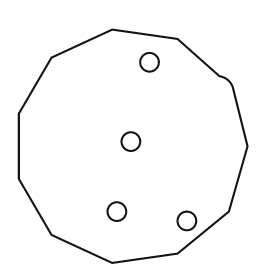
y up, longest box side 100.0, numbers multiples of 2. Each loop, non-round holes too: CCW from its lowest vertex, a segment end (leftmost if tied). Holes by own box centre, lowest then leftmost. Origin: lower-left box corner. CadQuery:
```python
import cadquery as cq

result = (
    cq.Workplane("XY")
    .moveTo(40.0, 0.0)
    .lineTo(68.0, 4.0)
    .lineTo(90.0, 22.0)
    .lineTo(98.0, 50.0)
    .lineTo(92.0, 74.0)
    .threePointArc((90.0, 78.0), (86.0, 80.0))
    .lineTo(68.0, 96.0)
    .lineTo(40.0, 100.0)
    .lineTo(14.0, 88.0)
    .lineTo(0.0, 64.0)
    .lineTo(0.0, 36.0)
    .lineTo(14.0, 12.0)
    .close()
    .moveTo(72.0, 18.0)
    .circle(4.0)
    .moveTo(42.0, 22.0)
    .circle(4.0)
    .moveTo(48.0, 52.0)
    .circle(4.0)
    .moveTo(56.0, 86.0)
    .circle(4.0)
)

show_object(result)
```